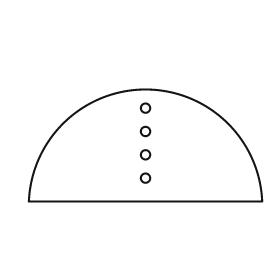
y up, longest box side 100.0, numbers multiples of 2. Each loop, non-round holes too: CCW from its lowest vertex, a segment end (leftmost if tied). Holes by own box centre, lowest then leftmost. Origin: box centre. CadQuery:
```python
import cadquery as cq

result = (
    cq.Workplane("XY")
    .moveTo(-50.0, -24.0)
    .lineTo(50.0, -24.0)
    .threePointArc((0.0, 24.0), (-50.0, -24.0))
    .close()
    .moveTo(0.0, -14.0)
    .circle(2.0)
    .moveTo(0.0, -4.0)
    .circle(2.0)
    .moveTo(0.0, 6.0)
    .circle(2.0)
    .moveTo(0.0, 16.0)
    .circle(2.0)
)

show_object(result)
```